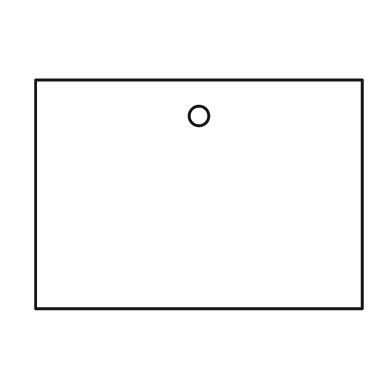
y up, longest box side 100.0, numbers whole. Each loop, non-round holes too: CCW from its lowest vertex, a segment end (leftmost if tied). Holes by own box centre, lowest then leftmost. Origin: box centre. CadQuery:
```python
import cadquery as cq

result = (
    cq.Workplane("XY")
    .moveTo(-50.0, -35.0)
    .lineTo(50.0, -35.0)
    .lineTo(50.0, 35.0)
    .lineTo(-50.0, 35.0)
    .close()
    .moveTo(0.0, 24.0)
    .circle(3.0)
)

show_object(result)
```